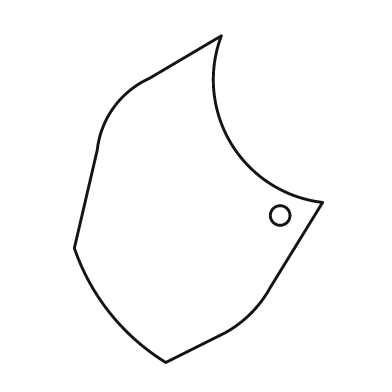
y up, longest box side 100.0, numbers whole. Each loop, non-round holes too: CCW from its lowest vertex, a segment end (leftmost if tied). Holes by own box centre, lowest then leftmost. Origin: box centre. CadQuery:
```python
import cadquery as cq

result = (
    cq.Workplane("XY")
    .moveTo(-10.0, -50.0)
    .lineTo(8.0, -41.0)
    .threePointArc((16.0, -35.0), (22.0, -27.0))
    .lineTo(38.0, -1.0)
    .threePointArc((10.0, 17.0), (7.0, 50.0))
    .lineTo(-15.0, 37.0)
    .threePointArc((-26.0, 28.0), (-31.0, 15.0))
    .lineTo(-38.0, -15.0)
    .threePointArc((-27.0, -35.0), (-10.0, -50.0))
    .close()
    .moveTo(25.0, -5.0)
    .circle(3.0)
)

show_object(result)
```